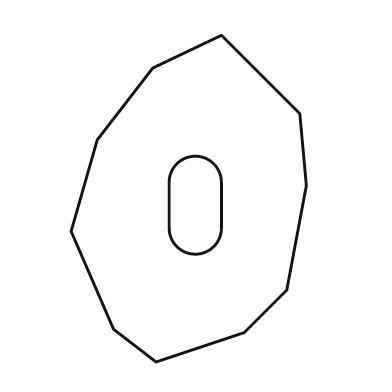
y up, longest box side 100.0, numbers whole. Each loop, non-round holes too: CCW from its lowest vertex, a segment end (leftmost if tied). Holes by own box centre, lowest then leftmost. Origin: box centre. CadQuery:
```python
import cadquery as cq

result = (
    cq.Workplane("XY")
    .moveTo(-10.0, -50.0)
    .lineTo(17.0, -41.0)
    .lineTo(30.0, -28.0)
    .lineTo(36.0, 4.0)
    .lineTo(34.0, 26.0)
    .lineTo(10.0, 50.0)
    .lineTo(-11.0, 40.0)
    .lineTo(-28.0, 18.0)
    .lineTo(-36.0, -10.0)
    .lineTo(-23.0, -40.0)
    .close()
    .moveTo(-6.0, -9.0)
    .threePointArc((2.0, -17.0), (10.0, -9.0))
    .lineTo(10.0, 5.0)
    .threePointArc((2.0, 13.0), (-6.0, 5.0))
    .close()
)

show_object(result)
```